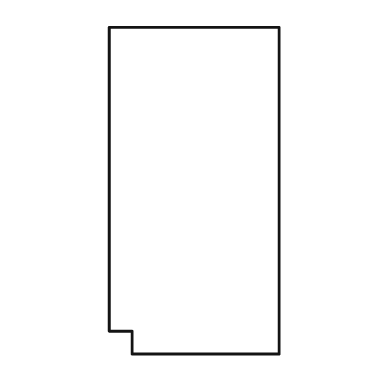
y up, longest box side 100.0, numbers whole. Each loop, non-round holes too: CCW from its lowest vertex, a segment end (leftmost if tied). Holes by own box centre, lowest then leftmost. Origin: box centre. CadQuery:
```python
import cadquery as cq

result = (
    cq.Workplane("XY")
    .moveTo(-19.0, -50.0)
    .lineTo(26.0, -50.0)
    .lineTo(26.0, 50.0)
    .lineTo(-26.0, 50.0)
    .lineTo(-26.0, -43.0)
    .lineTo(-19.0, -43.0)
    .close()
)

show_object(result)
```